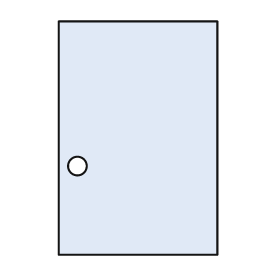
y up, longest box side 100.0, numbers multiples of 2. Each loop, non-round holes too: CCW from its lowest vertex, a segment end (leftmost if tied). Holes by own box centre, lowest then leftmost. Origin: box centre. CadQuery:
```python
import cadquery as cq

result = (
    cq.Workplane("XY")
    .moveTo(-34.0, -50.0)
    .lineTo(34.0, -50.0)
    .lineTo(34.0, 50.0)
    .lineTo(-34.0, 50.0)
    .close()
    .moveTo(-26.0, -12.0)
    .circle(4.0)
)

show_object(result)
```